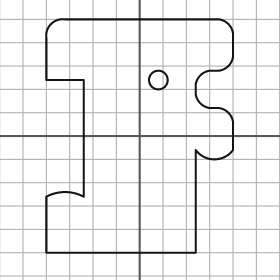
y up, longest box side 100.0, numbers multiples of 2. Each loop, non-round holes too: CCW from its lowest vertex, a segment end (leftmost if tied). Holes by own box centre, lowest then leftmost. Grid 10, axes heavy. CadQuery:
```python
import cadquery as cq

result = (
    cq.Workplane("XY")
    .moveTo(-40.0, -50.0)
    .lineTo(24.0, -50.0)
    .lineTo(24.0, -6.0)
    .threePointArc((32.0, -10.0), (40.0, -6.0))
    .lineTo(40.0, 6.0)
    .threePointArc((38.0, 10.0), (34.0, 12.0))
    .lineTo(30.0, 12.0)
    .threePointArc((26.0, 14.0), (24.0, 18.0))
    .lineTo(24.0, 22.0)
    .threePointArc((26.0, 26.0), (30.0, 28.0))
    .lineTo(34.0, 28.0)
    .threePointArc((38.0, 30.0), (40.0, 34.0))
    .lineTo(40.0, 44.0)
    .threePointArc((38.0, 48.0), (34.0, 50.0))
    .lineTo(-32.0, 50.0)
    .threePointArc((-38.0, 48.0), (-40.0, 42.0))
    .lineTo(-40.0, 24.0)
    .lineTo(-24.0, 24.0)
    .lineTo(-24.0, -26.0)
    .threePointArc((-32.0, -24.0), (-40.0, -26.0))
    .close()
    .moveTo(8.0, 24.0)
    .circle(4.0)
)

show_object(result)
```